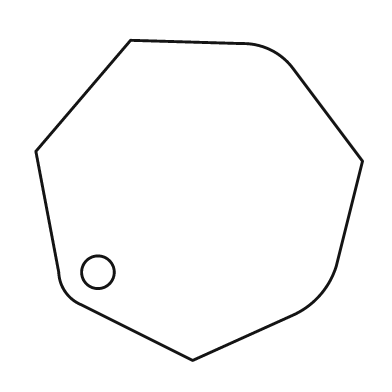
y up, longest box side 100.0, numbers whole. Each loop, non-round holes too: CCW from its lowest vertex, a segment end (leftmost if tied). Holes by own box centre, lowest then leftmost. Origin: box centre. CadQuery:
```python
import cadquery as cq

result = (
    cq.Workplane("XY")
    .moveTo(-2.0, -49.0)
    .lineTo(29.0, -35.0)
    .threePointArc((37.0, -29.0), (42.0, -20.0))
    .lineTo(50.0, 12.0)
    .lineTo(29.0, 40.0)
    .threePointArc((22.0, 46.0), (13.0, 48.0))
    .lineTo(-21.0, 49.0)
    .lineTo(-50.0, 15.0)
    .lineTo(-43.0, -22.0)
    .threePointArc((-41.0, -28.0), (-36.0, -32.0))
    .close()
    .moveTo(-31.0, -22.0)
    .circle(5.0)
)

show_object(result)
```